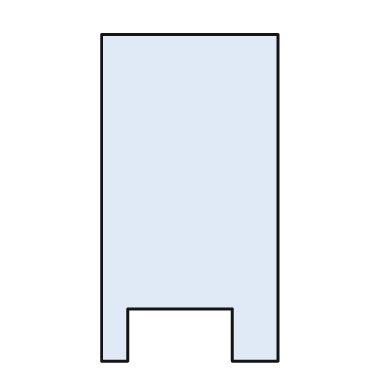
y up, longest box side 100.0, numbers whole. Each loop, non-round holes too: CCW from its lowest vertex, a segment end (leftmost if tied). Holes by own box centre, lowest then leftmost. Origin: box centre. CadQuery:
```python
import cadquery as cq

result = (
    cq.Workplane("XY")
    .moveTo(-27.0, -50.0)
    .lineTo(-19.0, -50.0)
    .lineTo(-19.0, -34.0)
    .lineTo(13.0, -34.0)
    .lineTo(13.0, -50.0)
    .lineTo(27.0, -50.0)
    .lineTo(27.0, 50.0)
    .lineTo(-27.0, 50.0)
    .close()
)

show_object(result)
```